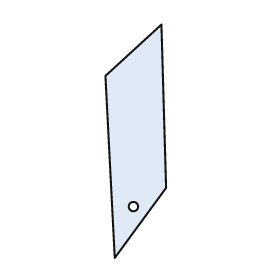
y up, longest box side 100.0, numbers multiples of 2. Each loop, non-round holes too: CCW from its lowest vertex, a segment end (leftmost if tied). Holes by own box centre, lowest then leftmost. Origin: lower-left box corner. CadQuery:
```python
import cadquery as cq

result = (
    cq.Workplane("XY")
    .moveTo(4.0, 0.0)
    .lineTo(26.0, 30.0)
    .lineTo(24.0, 100.0)
    .lineTo(0.0, 78.0)
    .close()
    .moveTo(12.0, 22.0)
    .circle(2.0)
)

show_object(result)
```